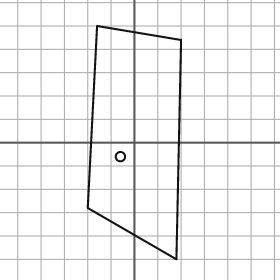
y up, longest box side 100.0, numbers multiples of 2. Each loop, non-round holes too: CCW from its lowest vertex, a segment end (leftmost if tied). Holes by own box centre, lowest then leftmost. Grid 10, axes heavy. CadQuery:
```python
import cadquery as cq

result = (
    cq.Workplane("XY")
    .moveTo(18.0, -50.0)
    .lineTo(20.0, 44.0)
    .lineTo(-16.0, 50.0)
    .lineTo(-20.0, -28.0)
    .close()
    .moveTo(-6.0, -6.0)
    .circle(2.0)
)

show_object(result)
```